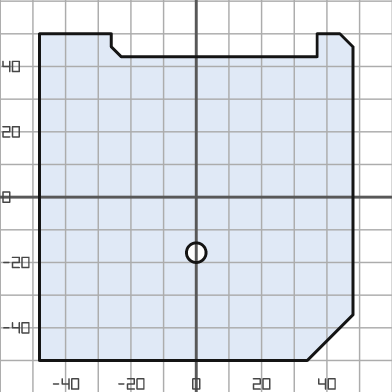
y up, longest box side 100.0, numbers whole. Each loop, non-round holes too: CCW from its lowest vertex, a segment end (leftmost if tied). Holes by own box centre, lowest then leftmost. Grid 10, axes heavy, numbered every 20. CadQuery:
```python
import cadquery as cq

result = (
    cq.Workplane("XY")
    .moveTo(-48.0, -50.0)
    .lineTo(34.0, -50.0)
    .lineTo(48.0, -36.0)
    .lineTo(48.0, 46.0)
    .lineTo(44.0, 50.0)
    .lineTo(37.0, 50.0)
    .lineTo(37.0, 43.0)
    .lineTo(-23.0, 43.0)
    .lineTo(-26.0, 46.0)
    .lineTo(-26.0, 50.0)
    .lineTo(-48.0, 50.0)
    .close()
    .moveTo(0.0, -17.0)
    .circle(3.0)
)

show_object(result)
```